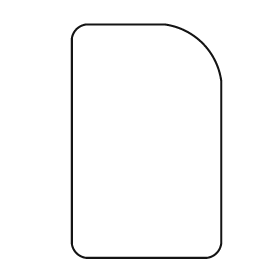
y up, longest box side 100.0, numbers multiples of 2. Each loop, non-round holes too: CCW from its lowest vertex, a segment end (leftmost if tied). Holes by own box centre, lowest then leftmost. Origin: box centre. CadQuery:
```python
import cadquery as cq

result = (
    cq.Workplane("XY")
    .moveTo(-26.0, -50.0)
    .lineTo(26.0, -50.0)
    .threePointArc((30.0, -48.0), (32.0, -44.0))
    .lineTo(32.0, 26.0)
    .threePointArc((24.0, 42.0), (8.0, 50.0))
    .lineTo(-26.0, 50.0)
    .threePointArc((-30.0, 48.0), (-32.0, 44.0))
    .lineTo(-32.0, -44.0)
    .threePointArc((-30.0, -48.0), (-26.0, -50.0))
    .close()
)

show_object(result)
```